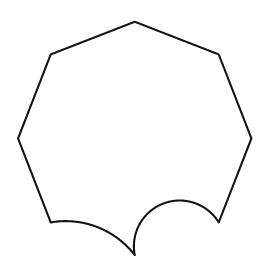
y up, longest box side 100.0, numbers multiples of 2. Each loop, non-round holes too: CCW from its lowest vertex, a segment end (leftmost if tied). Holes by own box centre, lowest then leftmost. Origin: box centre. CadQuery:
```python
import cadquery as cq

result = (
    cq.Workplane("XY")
    .moveTo(0.0, -50.0)
    .threePointArc((12.0, -28.0), (36.0, -36.0))
    .lineTo(50.0, 0.0)
    .lineTo(36.0, 36.0)
    .lineTo(0.0, 50.0)
    .lineTo(-36.0, 36.0)
    .lineTo(-50.0, 0.0)
    .lineTo(-36.0, -36.0)
    .threePointArc((-16.0, -38.0), (0.0, -50.0))
    .close()
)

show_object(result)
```